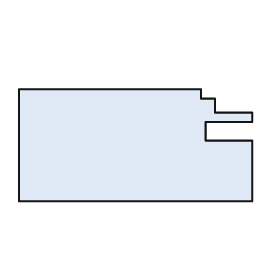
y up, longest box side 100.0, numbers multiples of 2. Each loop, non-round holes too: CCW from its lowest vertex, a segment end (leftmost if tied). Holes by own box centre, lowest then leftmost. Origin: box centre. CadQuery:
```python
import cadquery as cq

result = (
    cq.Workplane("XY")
    .moveTo(-50.0, -24.0)
    .lineTo(50.0, -24.0)
    .lineTo(50.0, 2.0)
    .lineTo(30.0, 2.0)
    .lineTo(30.0, 10.0)
    .lineTo(50.0, 10.0)
    .lineTo(50.0, 14.0)
    .lineTo(34.0, 14.0)
    .lineTo(34.0, 20.0)
    .lineTo(28.0, 20.0)
    .lineTo(28.0, 24.0)
    .lineTo(-50.0, 24.0)
    .close()
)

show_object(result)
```